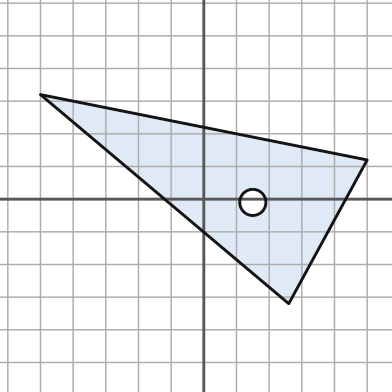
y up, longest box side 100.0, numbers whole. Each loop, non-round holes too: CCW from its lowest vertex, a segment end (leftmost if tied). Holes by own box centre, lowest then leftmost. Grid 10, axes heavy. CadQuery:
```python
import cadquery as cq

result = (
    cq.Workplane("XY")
    .moveTo(26.0, -32.0)
    .lineTo(50.0, 12.0)
    .lineTo(-50.0, 32.0)
    .close()
    .moveTo(15.0, -1.0)
    .circle(4.0)
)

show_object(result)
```